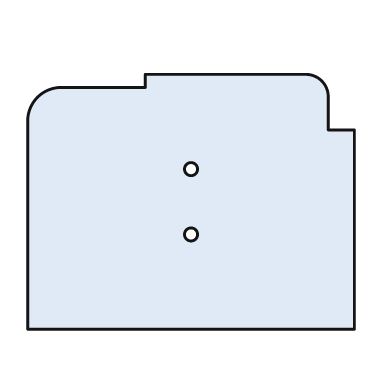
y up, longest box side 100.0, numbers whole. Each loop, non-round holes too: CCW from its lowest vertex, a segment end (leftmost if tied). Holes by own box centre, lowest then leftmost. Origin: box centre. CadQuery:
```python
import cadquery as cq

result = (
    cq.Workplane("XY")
    .moveTo(-50.0, -39.0)
    .lineTo(50.0, -39.0)
    .lineTo(50.0, 22.0)
    .lineTo(42.0, 22.0)
    .lineTo(42.0, 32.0)
    .threePointArc((40.0, 37.0), (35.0, 39.0))
    .lineTo(-14.0, 39.0)
    .lineTo(-14.0, 35.0)
    .lineTo(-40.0, 35.0)
    .threePointArc((-47.0, 32.0), (-50.0, 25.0))
    .close()
    .moveTo(0.0, -10.0)
    .circle(2.0)
    .moveTo(0.0, 10.0)
    .circle(2.0)
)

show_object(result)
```